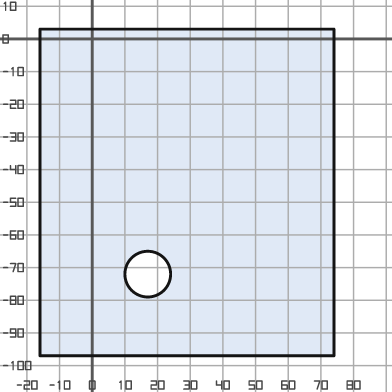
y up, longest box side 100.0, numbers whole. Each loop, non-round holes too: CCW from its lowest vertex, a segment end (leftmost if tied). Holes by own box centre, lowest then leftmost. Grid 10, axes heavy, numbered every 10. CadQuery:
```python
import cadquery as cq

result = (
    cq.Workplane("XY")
    .moveTo(-16.0, -97.0)
    .lineTo(74.0, -97.0)
    .lineTo(74.0, 3.0)
    .lineTo(-16.0, 3.0)
    .close()
    .moveTo(17.0, -72.0)
    .circle(7.0)
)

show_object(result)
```